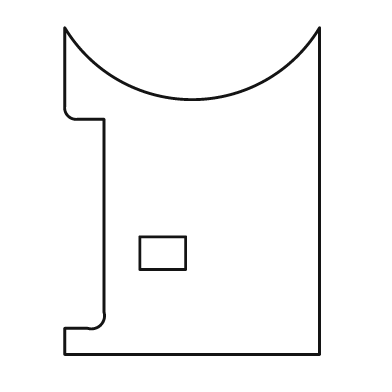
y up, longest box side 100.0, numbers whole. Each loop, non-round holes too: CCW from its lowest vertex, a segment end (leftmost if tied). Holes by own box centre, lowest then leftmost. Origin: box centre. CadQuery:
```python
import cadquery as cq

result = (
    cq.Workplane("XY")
    .moveTo(-39.0, -50.0)
    .lineTo(39.0, -50.0)
    .lineTo(39.0, 50.0)
    .threePointArc((0.0, 28.0), (-39.0, 50.0))
    .lineTo(-39.0, 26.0)
    .threePointArc((-38.0, 23.0), (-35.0, 22.0))
    .lineTo(-27.0, 22.0)
    .lineTo(-27.0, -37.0)
    .threePointArc((-28.0, -41.0), (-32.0, -42.0))
    .lineTo(-39.0, -42.0)
    .close()
    .moveTo(-16.0, -24.0)
    .lineTo(-2.0, -24.0)
    .lineTo(-2.0, -14.0)
    .lineTo(-16.0, -14.0)
    .close()
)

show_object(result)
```